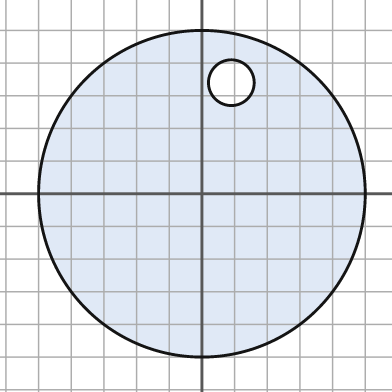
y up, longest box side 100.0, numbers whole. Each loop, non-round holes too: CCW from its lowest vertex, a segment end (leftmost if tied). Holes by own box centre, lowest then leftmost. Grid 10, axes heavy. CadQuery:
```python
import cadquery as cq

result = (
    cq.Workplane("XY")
    .moveTo(0.0, 0.0)
    .circle(50.0)
    .moveTo(9.0, 34.0)
    .circle(7.0)
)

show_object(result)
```